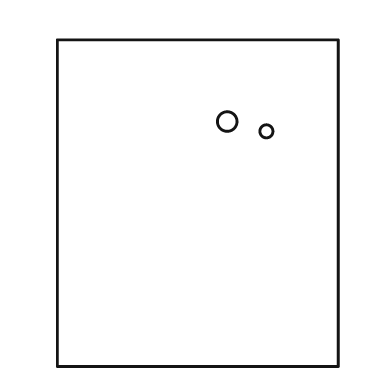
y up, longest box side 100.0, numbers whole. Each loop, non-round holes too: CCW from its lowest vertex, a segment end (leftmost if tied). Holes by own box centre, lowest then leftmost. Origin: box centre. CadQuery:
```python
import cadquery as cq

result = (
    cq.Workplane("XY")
    .moveTo(-43.0, -50.0)
    .lineTo(43.0, -50.0)
    .lineTo(43.0, 50.0)
    .lineTo(-43.0, 50.0)
    .close()
    .moveTo(21.0, 22.0)
    .circle(2.0)
    .moveTo(9.0, 25.0)
    .circle(3.0)
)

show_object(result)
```